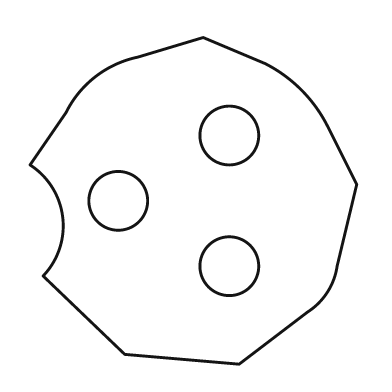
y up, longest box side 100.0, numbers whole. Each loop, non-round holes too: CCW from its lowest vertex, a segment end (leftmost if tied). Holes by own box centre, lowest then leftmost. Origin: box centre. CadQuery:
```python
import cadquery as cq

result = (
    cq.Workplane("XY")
    .moveTo(14.0, -50.0)
    .lineTo(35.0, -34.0)
    .threePointArc((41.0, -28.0), (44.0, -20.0))
    .lineTo(50.0, 5.0)
    .lineTo(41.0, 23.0)
    .threePointArc((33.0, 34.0), (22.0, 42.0))
    .lineTo(3.0, 50.0)
    .lineTo(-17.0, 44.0)
    .threePointArc((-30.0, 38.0), (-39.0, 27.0))
    .lineTo(-50.0, 11.0)
    .threePointArc((-40.0, -5.0), (-46.0, -23.0))
    .lineTo(-21.0, -47.0)
    .close()
    .moveTo(11.0, -20.0)
    .circle(9.0)
    .moveTo(-23.0, 0.0)
    .circle(9.0)
    .moveTo(11.0, 20.0)
    .circle(9.0)
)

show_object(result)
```